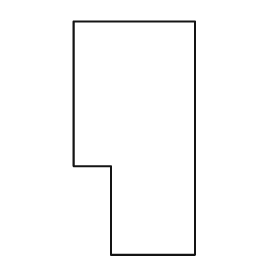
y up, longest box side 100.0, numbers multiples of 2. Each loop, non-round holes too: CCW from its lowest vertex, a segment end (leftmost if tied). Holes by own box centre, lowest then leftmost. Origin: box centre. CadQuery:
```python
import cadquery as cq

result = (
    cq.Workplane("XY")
    .moveTo(-10.0, -50.0)
    .lineTo(26.0, -50.0)
    .lineTo(26.0, 50.0)
    .lineTo(-26.0, 50.0)
    .lineTo(-26.0, -12.0)
    .lineTo(-10.0, -12.0)
    .close()
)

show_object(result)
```